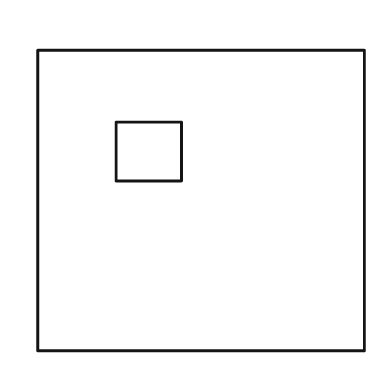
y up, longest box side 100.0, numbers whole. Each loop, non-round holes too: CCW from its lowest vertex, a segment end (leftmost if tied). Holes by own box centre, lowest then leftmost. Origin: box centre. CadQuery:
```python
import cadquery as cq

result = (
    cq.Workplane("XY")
    .moveTo(-50.0, -46.0)
    .lineTo(50.0, -46.0)
    .lineTo(50.0, 46.0)
    .lineTo(-50.0, 46.0)
    .close()
    .moveTo(-26.0, 6.0)
    .lineTo(-6.0, 6.0)
    .lineTo(-6.0, 24.0)
    .lineTo(-26.0, 24.0)
    .close()
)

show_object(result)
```